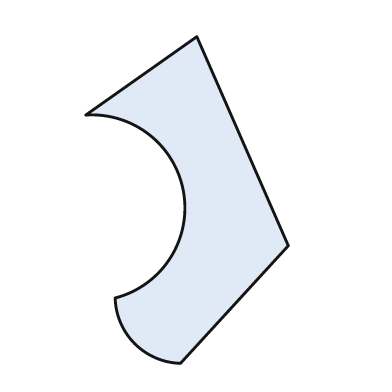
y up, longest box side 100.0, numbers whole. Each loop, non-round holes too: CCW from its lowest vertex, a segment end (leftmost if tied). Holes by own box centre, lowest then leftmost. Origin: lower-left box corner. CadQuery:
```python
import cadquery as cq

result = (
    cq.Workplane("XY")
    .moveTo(29.0, 0.0)
    .lineTo(62.0, 36.0)
    .lineTo(34.0, 100.0)
    .lineTo(0.0, 76.0)
    .threePointArc((30.0, 52.0), (9.0, 20.0))
    .threePointArc((15.0, 6.0), (29.0, 0.0))
    .close()
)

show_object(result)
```